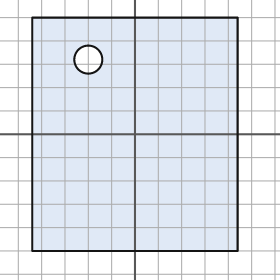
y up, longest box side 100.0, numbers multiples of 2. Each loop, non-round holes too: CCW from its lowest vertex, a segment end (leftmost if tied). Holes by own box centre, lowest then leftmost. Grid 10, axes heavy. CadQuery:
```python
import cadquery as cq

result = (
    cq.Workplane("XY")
    .moveTo(-44.0, -50.0)
    .lineTo(44.0, -50.0)
    .lineTo(44.0, 50.0)
    .lineTo(-44.0, 50.0)
    .close()
    .moveTo(-20.0, 32.0)
    .circle(6.0)
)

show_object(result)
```